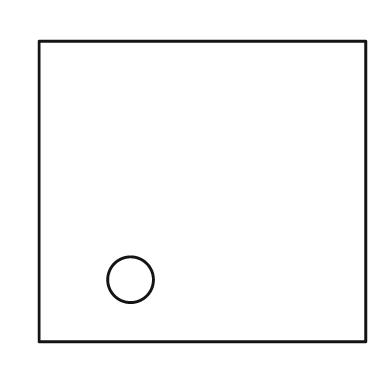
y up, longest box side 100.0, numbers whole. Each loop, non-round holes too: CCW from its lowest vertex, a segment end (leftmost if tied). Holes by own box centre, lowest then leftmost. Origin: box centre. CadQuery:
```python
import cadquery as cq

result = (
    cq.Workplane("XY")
    .moveTo(-50.0, -46.0)
    .lineTo(50.0, -46.0)
    .lineTo(50.0, 46.0)
    .lineTo(-50.0, 46.0)
    .close()
    .moveTo(-22.0, -27.0)
    .circle(7.0)
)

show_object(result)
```